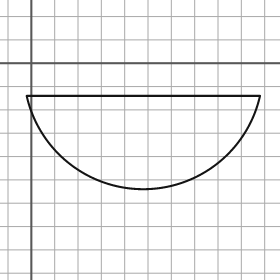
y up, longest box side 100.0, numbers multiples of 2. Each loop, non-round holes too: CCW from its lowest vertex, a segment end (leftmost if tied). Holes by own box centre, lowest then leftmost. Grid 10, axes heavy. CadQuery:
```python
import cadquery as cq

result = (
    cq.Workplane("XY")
    .moveTo(-2.0, -14.0)
    .threePointArc((48.0, -54.0), (98.0, -14.0))
    .close()
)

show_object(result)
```